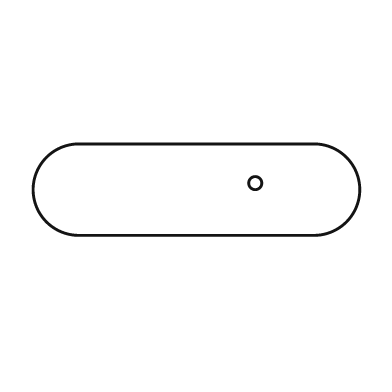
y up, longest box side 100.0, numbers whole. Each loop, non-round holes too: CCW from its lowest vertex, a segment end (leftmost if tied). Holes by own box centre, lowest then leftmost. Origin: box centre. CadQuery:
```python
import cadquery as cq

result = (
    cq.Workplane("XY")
    .moveTo(-36.0, -14.0)
    .lineTo(36.0, -14.0)
    .threePointArc((50.0, 0.0), (36.0, 14.0))
    .lineTo(-36.0, 14.0)
    .threePointArc((-50.0, 0.0), (-36.0, -14.0))
    .close()
    .moveTo(18.0, 2.0)
    .circle(2.0)
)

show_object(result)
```